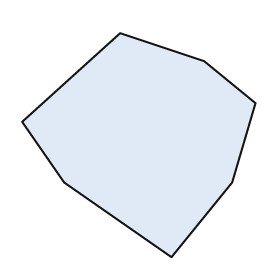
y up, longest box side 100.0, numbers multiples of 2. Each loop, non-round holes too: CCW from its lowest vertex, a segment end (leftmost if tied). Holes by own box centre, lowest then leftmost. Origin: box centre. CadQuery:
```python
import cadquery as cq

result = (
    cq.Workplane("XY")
    .moveTo(14.0, -48.0)
    .lineTo(40.0, -16.0)
    .lineTo(50.0, 18.0)
    .lineTo(28.0, 36.0)
    .lineTo(-8.0, 48.0)
    .lineTo(-50.0, 10.0)
    .lineTo(-32.0, -16.0)
    .close()
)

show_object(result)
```